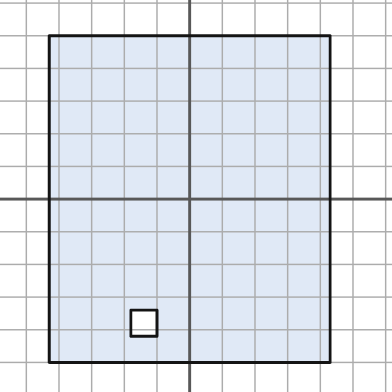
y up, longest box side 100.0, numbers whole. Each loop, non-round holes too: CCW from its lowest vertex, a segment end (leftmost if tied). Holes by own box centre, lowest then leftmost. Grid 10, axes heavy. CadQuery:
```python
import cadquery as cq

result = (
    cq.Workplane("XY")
    .moveTo(-43.0, -50.0)
    .lineTo(43.0, -50.0)
    .lineTo(43.0, 50.0)
    .lineTo(-43.0, 50.0)
    .close()
    .moveTo(-18.0, -42.0)
    .lineTo(-10.0, -42.0)
    .lineTo(-10.0, -34.0)
    .lineTo(-18.0, -34.0)
    .close()
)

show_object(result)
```